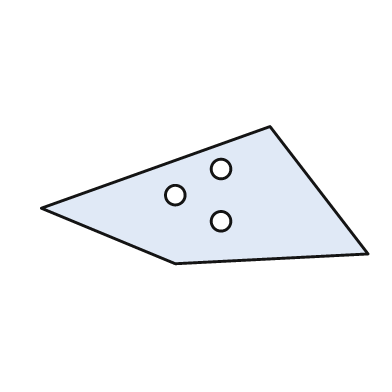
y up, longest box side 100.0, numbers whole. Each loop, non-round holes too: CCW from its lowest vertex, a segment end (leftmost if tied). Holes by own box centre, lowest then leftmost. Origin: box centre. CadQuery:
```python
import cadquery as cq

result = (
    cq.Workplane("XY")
    .moveTo(-9.0, -21.0)
    .lineTo(50.0, -18.0)
    .lineTo(20.0, 21.0)
    .lineTo(-50.0, -4.0)
    .close()
    .moveTo(5.0, -8.0)
    .circle(3.0)
    .moveTo(-9.0, 0.0)
    .circle(3.0)
    .moveTo(5.0, 8.0)
    .circle(3.0)
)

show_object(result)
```